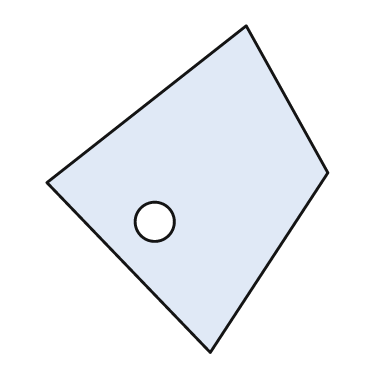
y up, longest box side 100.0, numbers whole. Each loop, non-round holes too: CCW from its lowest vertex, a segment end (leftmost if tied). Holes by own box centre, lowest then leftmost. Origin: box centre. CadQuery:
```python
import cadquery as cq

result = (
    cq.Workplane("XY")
    .moveTo(7.0, -50.0)
    .lineTo(43.0, 5.0)
    .lineTo(18.0, 50.0)
    .lineTo(-43.0, 2.0)
    .close()
    .moveTo(-10.0, -10.0)
    .circle(6.0)
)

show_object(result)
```